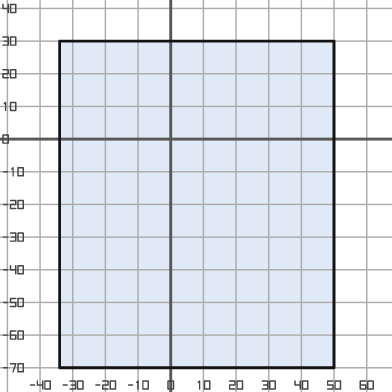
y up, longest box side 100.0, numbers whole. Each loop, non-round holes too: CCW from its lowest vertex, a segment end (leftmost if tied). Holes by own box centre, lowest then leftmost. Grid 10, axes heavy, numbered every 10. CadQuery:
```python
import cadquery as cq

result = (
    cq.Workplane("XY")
    .moveTo(-34.0, -70.0)
    .lineTo(50.0, -70.0)
    .lineTo(50.0, 30.0)
    .lineTo(-34.0, 30.0)
    .close()
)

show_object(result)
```